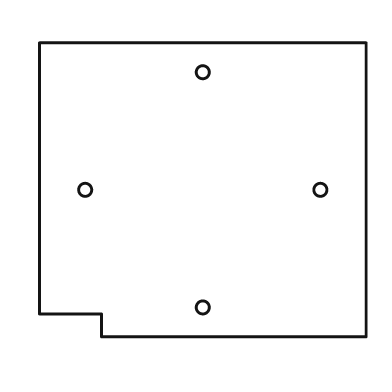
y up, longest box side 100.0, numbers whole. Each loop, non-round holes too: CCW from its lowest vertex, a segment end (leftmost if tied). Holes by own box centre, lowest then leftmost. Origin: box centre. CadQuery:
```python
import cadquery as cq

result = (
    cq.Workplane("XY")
    .moveTo(-31.0, -45.0)
    .lineTo(50.0, -45.0)
    .lineTo(50.0, 45.0)
    .lineTo(-50.0, 45.0)
    .lineTo(-50.0, -38.0)
    .lineTo(-31.0, -38.0)
    .close()
    .moveTo(0.0, -36.0)
    .circle(2.0)
    .moveTo(-36.0, 0.0)
    .circle(2.0)
    .moveTo(36.0, 0.0)
    .circle(2.0)
    .moveTo(0.0, 36.0)
    .circle(2.0)
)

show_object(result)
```